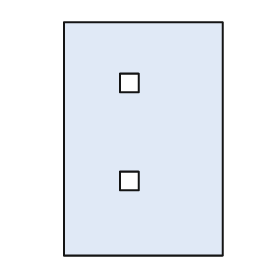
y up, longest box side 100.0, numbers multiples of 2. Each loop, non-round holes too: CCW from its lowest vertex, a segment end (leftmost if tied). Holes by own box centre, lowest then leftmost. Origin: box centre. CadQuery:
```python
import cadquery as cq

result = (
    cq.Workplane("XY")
    .moveTo(-34.0, -50.0)
    .lineTo(34.0, -50.0)
    .lineTo(34.0, 50.0)
    .lineTo(-34.0, 50.0)
    .close()
    .moveTo(-10.0, -22.0)
    .lineTo(-2.0, -22.0)
    .lineTo(-2.0, -14.0)
    .lineTo(-10.0, -14.0)
    .close()
    .moveTo(-10.0, 20.0)
    .lineTo(-2.0, 20.0)
    .lineTo(-2.0, 28.0)
    .lineTo(-10.0, 28.0)
    .close()
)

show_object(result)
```